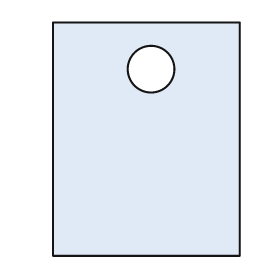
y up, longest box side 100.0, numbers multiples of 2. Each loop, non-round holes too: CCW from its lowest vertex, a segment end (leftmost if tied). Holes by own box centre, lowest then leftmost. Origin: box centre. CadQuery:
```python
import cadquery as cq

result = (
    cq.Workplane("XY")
    .moveTo(-40.0, -50.0)
    .lineTo(40.0, -50.0)
    .lineTo(40.0, 50.0)
    .lineTo(-40.0, 50.0)
    .close()
    .moveTo(2.0, 30.0)
    .circle(10.0)
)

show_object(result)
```